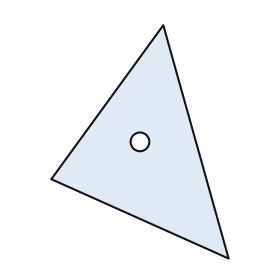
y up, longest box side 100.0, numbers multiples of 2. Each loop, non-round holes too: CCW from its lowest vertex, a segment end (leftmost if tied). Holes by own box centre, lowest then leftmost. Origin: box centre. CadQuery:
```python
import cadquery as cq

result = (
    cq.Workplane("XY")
    .moveTo(38.0, -50.0)
    .lineTo(10.0, 50.0)
    .lineTo(-38.0, -16.0)
    .close()
    .moveTo(0.0, 0.0)
    .circle(4.0)
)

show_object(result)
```